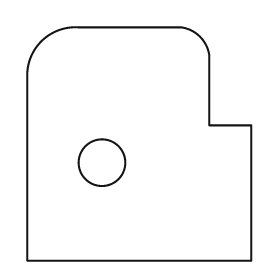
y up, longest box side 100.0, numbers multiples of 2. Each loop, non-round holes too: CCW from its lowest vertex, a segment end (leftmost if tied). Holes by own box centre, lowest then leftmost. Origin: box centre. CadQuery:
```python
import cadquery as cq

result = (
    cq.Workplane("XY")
    .moveTo(-48.0, -50.0)
    .lineTo(48.0, -50.0)
    .lineTo(48.0, 8.0)
    .lineTo(30.0, 8.0)
    .lineTo(30.0, 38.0)
    .threePointArc((26.0, 46.0), (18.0, 50.0))
    .lineTo(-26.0, 50.0)
    .threePointArc((-42.0, 44.0), (-48.0, 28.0))
    .close()
    .moveTo(-16.0, -8.0)
    .circle(10.0)
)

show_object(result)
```